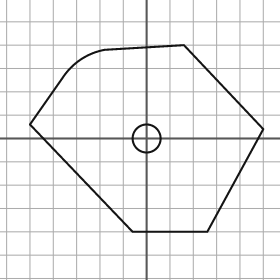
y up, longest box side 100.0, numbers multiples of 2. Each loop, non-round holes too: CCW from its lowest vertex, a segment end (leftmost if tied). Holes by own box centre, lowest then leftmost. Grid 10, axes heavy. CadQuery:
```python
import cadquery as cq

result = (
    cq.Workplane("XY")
    .moveTo(-6.0, -40.0)
    .lineTo(26.0, -40.0)
    .lineTo(50.0, 4.0)
    .lineTo(16.0, 40.0)
    .lineTo(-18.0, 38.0)
    .threePointArc((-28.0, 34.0), (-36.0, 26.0))
    .lineTo(-50.0, 6.0)
    .close()
    .moveTo(0.0, 0.0)
    .circle(6.0)
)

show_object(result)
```